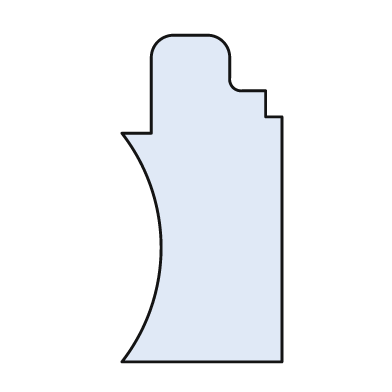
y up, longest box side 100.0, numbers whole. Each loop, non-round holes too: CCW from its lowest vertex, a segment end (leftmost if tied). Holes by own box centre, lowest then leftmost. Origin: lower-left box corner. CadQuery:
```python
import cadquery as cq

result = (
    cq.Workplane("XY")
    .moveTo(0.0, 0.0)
    .lineTo(49.0, 0.0)
    .lineTo(49.0, 75.0)
    .lineTo(44.0, 75.0)
    .lineTo(44.0, 83.0)
    .lineTo(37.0, 83.0)
    .threePointArc((34.0, 84.0), (33.0, 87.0))
    .lineTo(33.0, 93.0)
    .threePointArc((31.0, 98.0), (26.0, 100.0))
    .lineTo(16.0, 100.0)
    .threePointArc((11.0, 98.0), (9.0, 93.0))
    .lineTo(9.0, 70.0)
    .lineTo(0.0, 70.0)
    .threePointArc((12.0, 35.0), (0.0, 0.0))
    .close()
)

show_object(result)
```